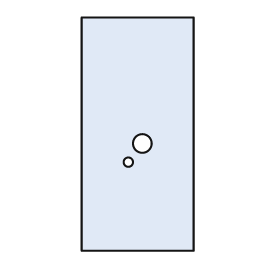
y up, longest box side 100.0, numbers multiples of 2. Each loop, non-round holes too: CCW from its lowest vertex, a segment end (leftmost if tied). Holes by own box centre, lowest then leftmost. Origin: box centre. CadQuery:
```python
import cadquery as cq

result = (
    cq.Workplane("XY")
    .moveTo(-24.0, -50.0)
    .lineTo(24.0, -50.0)
    .lineTo(24.0, 50.0)
    .lineTo(-24.0, 50.0)
    .close()
    .moveTo(-4.0, -12.0)
    .circle(2.0)
    .moveTo(2.0, -4.0)
    .circle(4.0)
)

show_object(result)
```